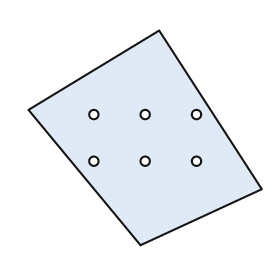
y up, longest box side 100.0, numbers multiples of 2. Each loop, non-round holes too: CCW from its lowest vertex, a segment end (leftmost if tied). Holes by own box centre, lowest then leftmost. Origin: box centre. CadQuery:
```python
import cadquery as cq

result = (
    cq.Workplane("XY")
    .moveTo(-2.0, -46.0)
    .lineTo(50.0, -22.0)
    .lineTo(6.0, 46.0)
    .lineTo(-50.0, 12.0)
    .close()
    .moveTo(-22.0, -10.0)
    .circle(2.0)
    .moveTo(0.0, -10.0)
    .circle(2.0)
    .moveTo(22.0, -10.0)
    .circle(2.0)
    .moveTo(-22.0, 10.0)
    .circle(2.0)
    .moveTo(0.0, 10.0)
    .circle(2.0)
    .moveTo(22.0, 10.0)
    .circle(2.0)
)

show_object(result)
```